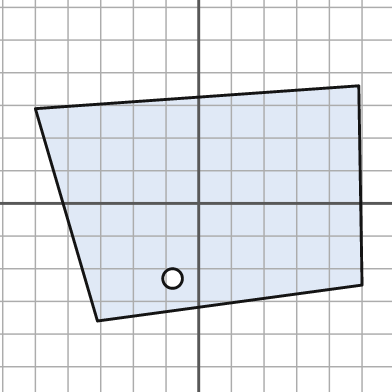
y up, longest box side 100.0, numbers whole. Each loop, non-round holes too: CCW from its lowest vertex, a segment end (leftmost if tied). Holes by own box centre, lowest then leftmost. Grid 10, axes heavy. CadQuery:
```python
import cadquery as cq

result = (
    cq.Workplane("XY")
    .moveTo(-31.0, -36.0)
    .lineTo(50.0, -25.0)
    .lineTo(49.0, 36.0)
    .lineTo(-50.0, 29.0)
    .close()
    .moveTo(-8.0, -23.0)
    .circle(3.0)
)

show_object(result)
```